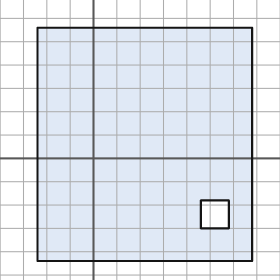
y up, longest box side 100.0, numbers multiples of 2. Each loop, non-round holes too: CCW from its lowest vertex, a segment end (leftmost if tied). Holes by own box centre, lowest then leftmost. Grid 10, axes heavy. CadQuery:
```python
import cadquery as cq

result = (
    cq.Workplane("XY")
    .moveTo(-24.0, -44.0)
    .lineTo(68.0, -44.0)
    .lineTo(68.0, 56.0)
    .lineTo(-24.0, 56.0)
    .close()
    .moveTo(46.0, -30.0)
    .lineTo(58.0, -30.0)
    .lineTo(58.0, -18.0)
    .lineTo(46.0, -18.0)
    .close()
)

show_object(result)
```